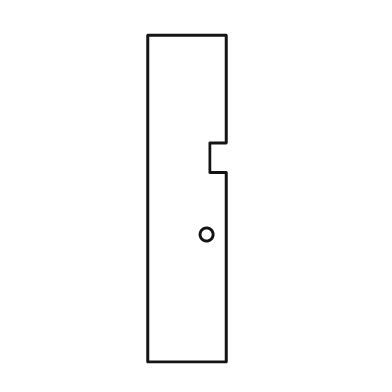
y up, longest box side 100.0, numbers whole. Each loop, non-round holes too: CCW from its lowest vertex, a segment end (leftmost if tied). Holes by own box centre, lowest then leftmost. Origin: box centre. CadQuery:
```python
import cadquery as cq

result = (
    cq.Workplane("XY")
    .moveTo(-12.0, -50.0)
    .lineTo(12.0, -50.0)
    .lineTo(12.0, 8.0)
    .lineTo(7.0, 8.0)
    .lineTo(7.0, 17.0)
    .lineTo(12.0, 17.0)
    .lineTo(12.0, 50.0)
    .lineTo(-12.0, 50.0)
    .close()
    .moveTo(6.0, -11.0)
    .circle(2.0)
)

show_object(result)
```